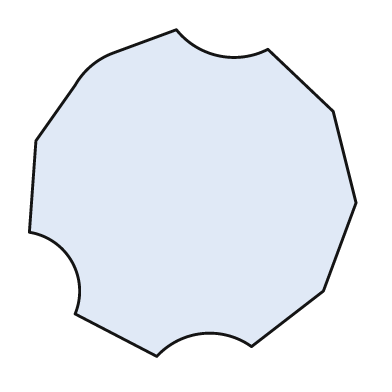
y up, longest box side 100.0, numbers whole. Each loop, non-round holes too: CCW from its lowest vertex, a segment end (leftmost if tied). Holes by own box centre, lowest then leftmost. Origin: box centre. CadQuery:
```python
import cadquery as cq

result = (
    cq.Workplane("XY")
    .moveTo(-11.0, -50.0)
    .threePointArc((3.0, -43.0), (18.0, -47.0))
    .lineTo(40.0, -30.0)
    .lineTo(50.0, -3.0)
    .lineTo(43.0, 25.0)
    .lineTo(23.0, 44.0)
    .threePointArc((8.0, 42.0), (-5.0, 50.0))
    .lineTo(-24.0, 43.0)
    .threePointArc((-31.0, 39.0), (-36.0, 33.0))
    .lineTo(-48.0, 16.0)
    .lineTo(-50.0, -12.0)
    .threePointArc((-37.0, -21.0), (-36.0, -37.0))
    .close()
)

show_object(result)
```